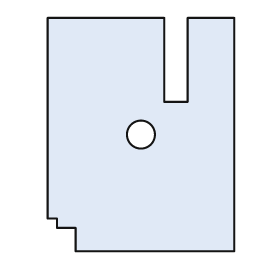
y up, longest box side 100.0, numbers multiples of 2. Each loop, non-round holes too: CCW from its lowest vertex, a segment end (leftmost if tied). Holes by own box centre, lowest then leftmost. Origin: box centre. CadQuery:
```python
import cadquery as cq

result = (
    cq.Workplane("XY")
    .moveTo(-28.0, -50.0)
    .lineTo(40.0, -50.0)
    .lineTo(40.0, 50.0)
    .lineTo(20.0, 50.0)
    .lineTo(20.0, 14.0)
    .lineTo(10.0, 14.0)
    .lineTo(10.0, 50.0)
    .lineTo(-40.0, 50.0)
    .lineTo(-40.0, -36.0)
    .lineTo(-36.0, -36.0)
    .lineTo(-36.0, -40.0)
    .lineTo(-28.0, -40.0)
    .close()
    .moveTo(0.0, 0.0)
    .circle(6.0)
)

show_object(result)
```